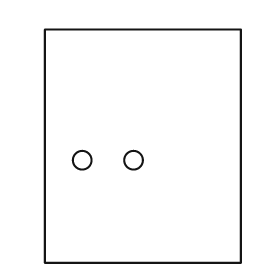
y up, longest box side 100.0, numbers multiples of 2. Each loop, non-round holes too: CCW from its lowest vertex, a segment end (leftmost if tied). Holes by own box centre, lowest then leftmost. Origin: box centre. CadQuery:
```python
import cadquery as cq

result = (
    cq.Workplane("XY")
    .moveTo(-42.0, -50.0)
    .lineTo(42.0, -50.0)
    .lineTo(42.0, 50.0)
    .lineTo(-42.0, 50.0)
    .close()
    .moveTo(-26.0, -6.0)
    .circle(4.0)
    .moveTo(-4.0, -6.0)
    .circle(4.0)
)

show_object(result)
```